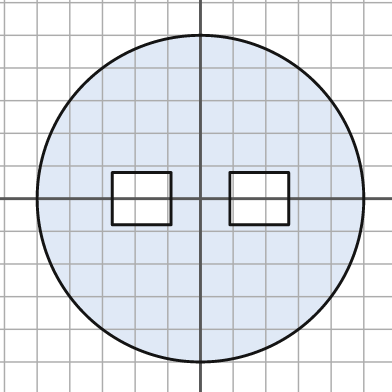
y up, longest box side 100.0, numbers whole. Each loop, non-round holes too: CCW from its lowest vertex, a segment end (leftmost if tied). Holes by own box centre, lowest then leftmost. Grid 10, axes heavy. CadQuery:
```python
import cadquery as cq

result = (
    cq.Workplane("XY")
    .moveTo(0.0, 0.0)
    .circle(50.0)
    .moveTo(-27.0, -8.0)
    .lineTo(-9.0, -8.0)
    .lineTo(-9.0, 8.0)
    .lineTo(-27.0, 8.0)
    .close()
    .moveTo(9.0, -8.0)
    .lineTo(27.0, -8.0)
    .lineTo(27.0, 8.0)
    .lineTo(9.0, 8.0)
    .close()
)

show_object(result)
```